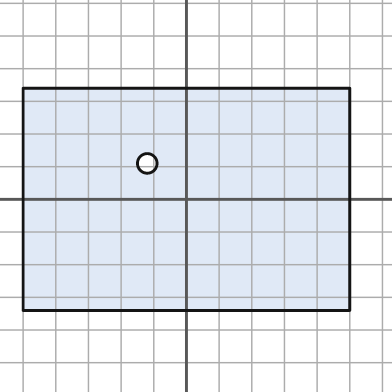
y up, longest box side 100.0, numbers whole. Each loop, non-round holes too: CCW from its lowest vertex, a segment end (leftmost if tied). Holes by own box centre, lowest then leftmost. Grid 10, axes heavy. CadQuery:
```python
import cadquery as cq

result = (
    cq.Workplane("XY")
    .moveTo(-50.0, -34.0)
    .lineTo(50.0, -34.0)
    .lineTo(50.0, 34.0)
    .lineTo(-50.0, 34.0)
    .close()
    .moveTo(-12.0, 11.0)
    .circle(3.0)
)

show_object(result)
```